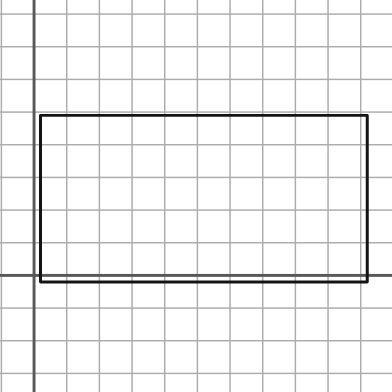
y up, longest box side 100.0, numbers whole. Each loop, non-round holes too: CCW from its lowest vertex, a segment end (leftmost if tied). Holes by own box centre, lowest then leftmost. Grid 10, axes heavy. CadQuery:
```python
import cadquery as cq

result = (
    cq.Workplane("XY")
    .moveTo(2.0, -2.0)
    .lineTo(102.0, -2.0)
    .lineTo(102.0, 49.0)
    .lineTo(2.0, 49.0)
    .close()
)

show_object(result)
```